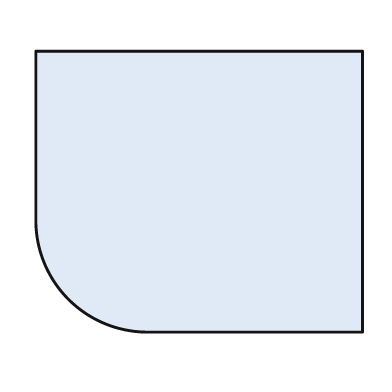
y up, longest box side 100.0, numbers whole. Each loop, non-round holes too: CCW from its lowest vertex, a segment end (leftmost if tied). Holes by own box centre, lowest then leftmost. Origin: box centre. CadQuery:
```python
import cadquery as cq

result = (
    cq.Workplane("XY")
    .moveTo(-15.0, -43.0)
    .lineTo(50.0, -43.0)
    .lineTo(50.0, 43.0)
    .lineTo(-50.0, 43.0)
    .lineTo(-50.0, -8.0)
    .threePointArc((-40.0, -33.0), (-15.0, -43.0))
    .close()
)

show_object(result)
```